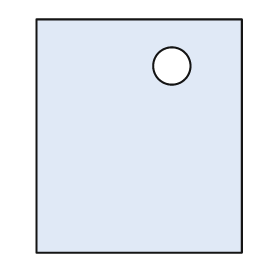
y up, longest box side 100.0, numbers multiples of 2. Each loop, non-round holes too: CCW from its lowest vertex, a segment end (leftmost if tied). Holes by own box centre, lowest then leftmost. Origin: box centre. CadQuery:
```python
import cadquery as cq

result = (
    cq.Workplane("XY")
    .moveTo(-44.0, -50.0)
    .lineTo(44.0, -50.0)
    .lineTo(44.0, 50.0)
    .lineTo(-44.0, 50.0)
    .close()
    .moveTo(14.0, 30.0)
    .circle(8.0)
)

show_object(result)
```